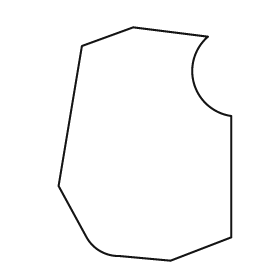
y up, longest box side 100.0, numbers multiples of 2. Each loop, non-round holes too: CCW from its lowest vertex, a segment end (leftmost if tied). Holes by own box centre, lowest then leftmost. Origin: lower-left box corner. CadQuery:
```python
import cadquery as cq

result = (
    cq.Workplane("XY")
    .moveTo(48.0, 0.0)
    .lineTo(74.0, 10.0)
    .lineTo(74.0, 62.0)
    .threePointArc((58.0, 76.0), (64.0, 96.0))
    .lineTo(32.0, 100.0)
    .lineTo(10.0, 92.0)
    .lineTo(0.0, 32.0)
    .lineTo(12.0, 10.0)
    .threePointArc((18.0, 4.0), (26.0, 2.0))
    .close()
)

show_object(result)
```